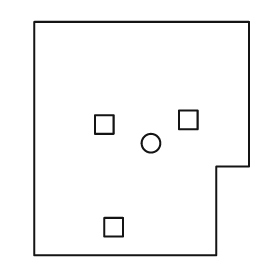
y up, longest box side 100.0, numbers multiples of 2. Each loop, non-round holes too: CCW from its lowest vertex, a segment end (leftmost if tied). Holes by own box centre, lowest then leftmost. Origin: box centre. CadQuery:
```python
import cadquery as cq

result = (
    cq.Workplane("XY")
    .moveTo(-46.0, -50.0)
    .lineTo(32.0, -50.0)
    .lineTo(32.0, -12.0)
    .lineTo(46.0, -12.0)
    .lineTo(46.0, 50.0)
    .lineTo(-46.0, 50.0)
    .close()
    .moveTo(-16.0, -42.0)
    .lineTo(-8.0, -42.0)
    .lineTo(-8.0, -34.0)
    .lineTo(-16.0, -34.0)
    .close()
    .moveTo(4.0, -2.0)
    .circle(4.0)
    .moveTo(-20.0, 2.0)
    .lineTo(-12.0, 2.0)
    .lineTo(-12.0, 10.0)
    .lineTo(-20.0, 10.0)
    .close()
    .moveTo(16.0, 4.0)
    .lineTo(24.0, 4.0)
    .lineTo(24.0, 12.0)
    .lineTo(16.0, 12.0)
    .close()
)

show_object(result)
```